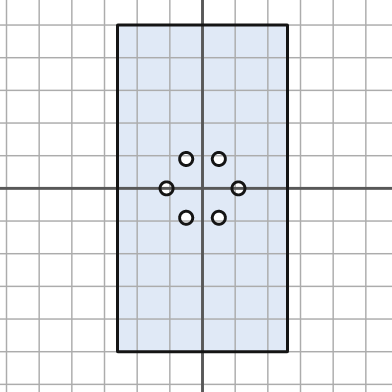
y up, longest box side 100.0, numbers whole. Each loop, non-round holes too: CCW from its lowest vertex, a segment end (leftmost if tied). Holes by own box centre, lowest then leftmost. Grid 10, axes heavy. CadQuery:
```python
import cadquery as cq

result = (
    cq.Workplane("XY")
    .moveTo(-26.0, -50.0)
    .lineTo(26.0, -50.0)
    .lineTo(26.0, 50.0)
    .lineTo(-26.0, 50.0)
    .close()
    .moveTo(-5.0, -9.0)
    .circle(2.0)
    .moveTo(5.0, -9.0)
    .circle(2.0)
    .moveTo(-11.0, 0.0)
    .circle(2.0)
    .moveTo(11.0, 0.0)
    .circle(2.0)
    .moveTo(-5.0, 9.0)
    .circle(2.0)
    .moveTo(5.0, 9.0)
    .circle(2.0)
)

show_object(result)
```